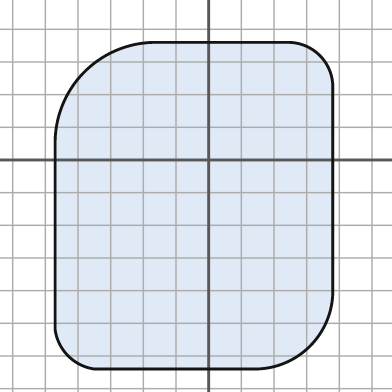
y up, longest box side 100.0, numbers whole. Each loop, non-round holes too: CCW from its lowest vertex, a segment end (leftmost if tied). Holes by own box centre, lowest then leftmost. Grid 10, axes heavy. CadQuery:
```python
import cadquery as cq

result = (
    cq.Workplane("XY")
    .moveTo(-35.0, -64.0)
    .lineTo(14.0, -64.0)
    .threePointArc((31.0, -57.0), (38.0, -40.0))
    .lineTo(38.0, 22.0)
    .threePointArc((34.0, 32.0), (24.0, 36.0))
    .lineTo(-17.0, 36.0)
    .threePointArc((-38.0, 27.0), (-47.0, 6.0))
    .lineTo(-47.0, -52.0)
    .threePointArc((-43.0, -60.0), (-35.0, -64.0))
    .close()
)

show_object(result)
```